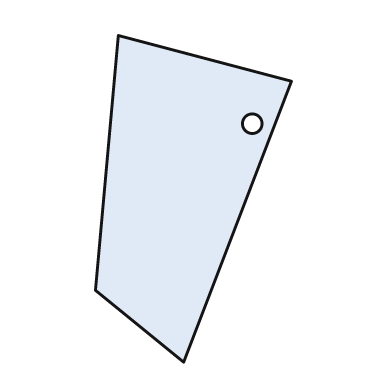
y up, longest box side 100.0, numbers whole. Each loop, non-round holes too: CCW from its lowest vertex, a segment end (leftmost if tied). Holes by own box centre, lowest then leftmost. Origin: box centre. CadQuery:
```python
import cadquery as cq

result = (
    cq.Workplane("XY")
    .moveTo(-3.0, -50.0)
    .lineTo(30.0, 36.0)
    .lineTo(-23.0, 50.0)
    .lineTo(-30.0, -28.0)
    .close()
    .moveTo(18.0, 23.0)
    .circle(3.0)
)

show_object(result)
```